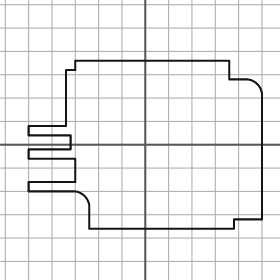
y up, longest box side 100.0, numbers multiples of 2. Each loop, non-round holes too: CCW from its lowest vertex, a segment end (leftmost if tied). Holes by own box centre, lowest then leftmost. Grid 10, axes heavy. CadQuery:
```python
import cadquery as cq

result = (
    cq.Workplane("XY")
    .moveTo(-24.0, -36.0)
    .lineTo(38.0, -36.0)
    .lineTo(38.0, -32.0)
    .lineTo(50.0, -32.0)
    .lineTo(50.0, 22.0)
    .threePointArc((48.0, 26.0), (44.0, 28.0))
    .lineTo(36.0, 28.0)
    .lineTo(36.0, 36.0)
    .lineTo(-30.0, 36.0)
    .lineTo(-30.0, 32.0)
    .lineTo(-34.0, 32.0)
    .lineTo(-34.0, 8.0)
    .lineTo(-50.0, 8.0)
    .lineTo(-50.0, 4.0)
    .lineTo(-32.0, 4.0)
    .lineTo(-32.0, -2.0)
    .lineTo(-50.0, -2.0)
    .lineTo(-50.0, -6.0)
    .lineTo(-30.0, -6.0)
    .lineTo(-30.0, -16.0)
    .lineTo(-50.0, -16.0)
    .lineTo(-50.0, -20.0)
    .lineTo(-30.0, -20.0)
    .threePointArc((-26.0, -22.0), (-24.0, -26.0))
    .close()
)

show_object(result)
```